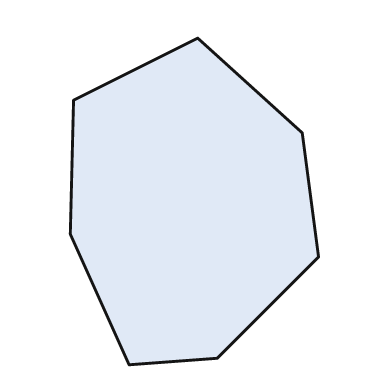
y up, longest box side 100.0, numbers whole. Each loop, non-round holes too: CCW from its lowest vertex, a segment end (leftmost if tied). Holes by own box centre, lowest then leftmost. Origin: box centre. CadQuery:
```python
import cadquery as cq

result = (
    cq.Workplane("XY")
    .moveTo(-20.0, -50.0)
    .lineTo(7.0, -48.0)
    .lineTo(38.0, -17.0)
    .lineTo(33.0, 21.0)
    .lineTo(1.0, 50.0)
    .lineTo(-37.0, 31.0)
    .lineTo(-38.0, -10.0)
    .close()
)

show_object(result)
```